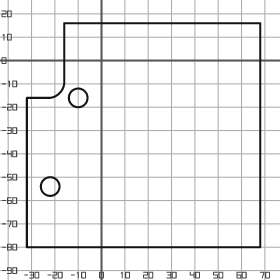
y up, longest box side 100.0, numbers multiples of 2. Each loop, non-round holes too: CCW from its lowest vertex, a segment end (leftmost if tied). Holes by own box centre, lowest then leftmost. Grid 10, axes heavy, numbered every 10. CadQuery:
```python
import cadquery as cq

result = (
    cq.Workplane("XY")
    .moveTo(-32.0, -80.0)
    .lineTo(68.0, -80.0)
    .lineTo(68.0, 16.0)
    .lineTo(-16.0, 16.0)
    .lineTo(-16.0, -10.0)
    .threePointArc((-18.0, -14.0), (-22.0, -16.0))
    .lineTo(-32.0, -16.0)
    .close()
    .moveTo(-22.0, -54.0)
    .circle(4.0)
    .moveTo(-10.0, -16.0)
    .circle(4.0)
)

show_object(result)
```